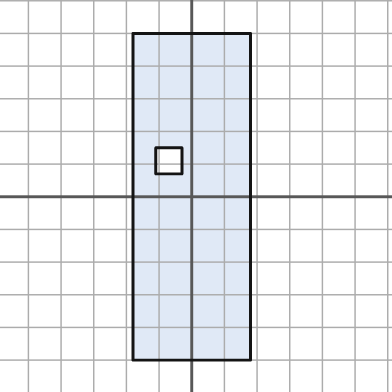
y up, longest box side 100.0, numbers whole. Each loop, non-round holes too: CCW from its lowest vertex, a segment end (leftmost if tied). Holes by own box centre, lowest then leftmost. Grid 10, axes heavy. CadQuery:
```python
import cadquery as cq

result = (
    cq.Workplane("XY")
    .moveTo(-18.0, -50.0)
    .lineTo(18.0, -50.0)
    .lineTo(18.0, 50.0)
    .lineTo(-18.0, 50.0)
    .close()
    .moveTo(-11.0, 7.0)
    .lineTo(-3.0, 7.0)
    .lineTo(-3.0, 15.0)
    .lineTo(-11.0, 15.0)
    .close()
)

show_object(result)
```